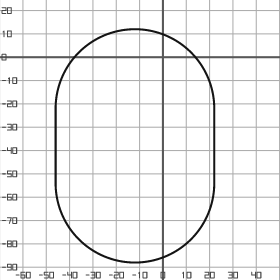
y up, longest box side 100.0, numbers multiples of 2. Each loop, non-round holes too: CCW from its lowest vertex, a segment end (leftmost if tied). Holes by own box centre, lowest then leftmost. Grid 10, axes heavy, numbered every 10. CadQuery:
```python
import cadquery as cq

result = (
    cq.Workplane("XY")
    .moveTo(-46.0, -54.0)
    .threePointArc((-12.0, -88.0), (22.0, -54.0))
    .lineTo(22.0, -22.0)
    .threePointArc((-12.0, 12.0), (-46.0, -22.0))
    .close()
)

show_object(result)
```